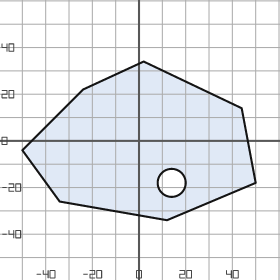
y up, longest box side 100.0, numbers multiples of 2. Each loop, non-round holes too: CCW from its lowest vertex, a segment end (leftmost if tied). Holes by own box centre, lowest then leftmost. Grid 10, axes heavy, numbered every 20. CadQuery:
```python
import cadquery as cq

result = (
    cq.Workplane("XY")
    .moveTo(12.0, -34.0)
    .lineTo(50.0, -18.0)
    .lineTo(44.0, 14.0)
    .lineTo(2.0, 34.0)
    .lineTo(-24.0, 22.0)
    .lineTo(-50.0, -4.0)
    .lineTo(-34.0, -26.0)
    .close()
    .moveTo(14.0, -18.0)
    .circle(6.0)
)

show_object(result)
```